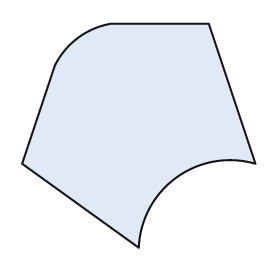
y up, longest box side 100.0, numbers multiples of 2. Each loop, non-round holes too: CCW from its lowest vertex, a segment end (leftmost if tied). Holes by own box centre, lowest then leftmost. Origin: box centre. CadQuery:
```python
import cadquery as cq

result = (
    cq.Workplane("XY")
    .moveTo(0.0, -48.0)
    .threePointArc((16.0, -18.0), (50.0, -12.0))
    .lineTo(30.0, 48.0)
    .lineTo(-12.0, 48.0)
    .threePointArc((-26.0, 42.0), (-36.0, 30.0))
    .lineTo(-50.0, -12.0)
    .close()
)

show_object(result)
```